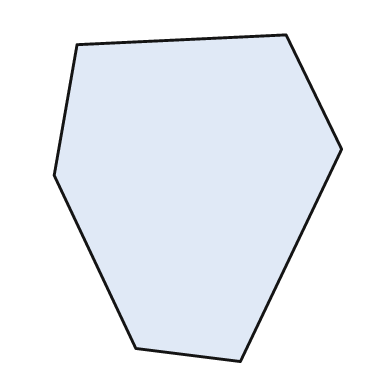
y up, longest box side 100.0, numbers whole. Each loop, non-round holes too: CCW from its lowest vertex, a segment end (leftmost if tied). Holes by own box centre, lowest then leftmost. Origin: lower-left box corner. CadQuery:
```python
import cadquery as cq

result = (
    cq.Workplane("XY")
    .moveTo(57.0, 0.0)
    .lineTo(88.0, 65.0)
    .lineTo(71.0, 100.0)
    .lineTo(7.0, 97.0)
    .lineTo(0.0, 57.0)
    .lineTo(25.0, 4.0)
    .close()
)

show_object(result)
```